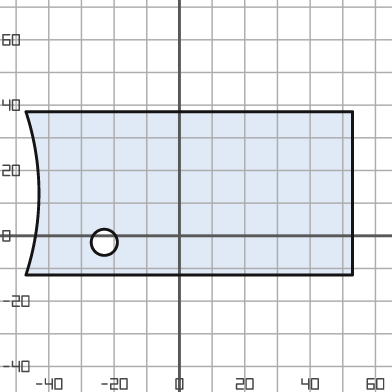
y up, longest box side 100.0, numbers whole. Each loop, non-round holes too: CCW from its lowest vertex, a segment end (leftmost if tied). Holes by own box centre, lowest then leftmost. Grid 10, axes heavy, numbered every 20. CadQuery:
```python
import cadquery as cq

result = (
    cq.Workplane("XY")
    .moveTo(-47.0, -12.0)
    .lineTo(53.0, -12.0)
    .lineTo(53.0, 38.0)
    .lineTo(-47.0, 38.0)
    .threePointArc((-43.0, 13.0), (-47.0, -12.0))
    .close()
    .moveTo(-23.0, -2.0)
    .circle(4.0)
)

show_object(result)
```